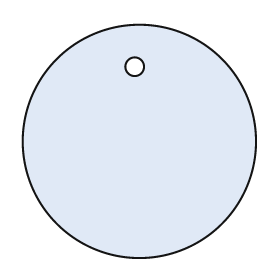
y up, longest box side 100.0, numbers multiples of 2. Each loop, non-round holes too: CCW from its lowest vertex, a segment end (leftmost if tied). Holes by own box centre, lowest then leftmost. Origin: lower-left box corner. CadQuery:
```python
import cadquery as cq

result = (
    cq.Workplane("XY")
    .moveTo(50.0, 50.0)
    .circle(50.0)
    .moveTo(48.0, 82.0)
    .circle(4.0)
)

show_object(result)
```